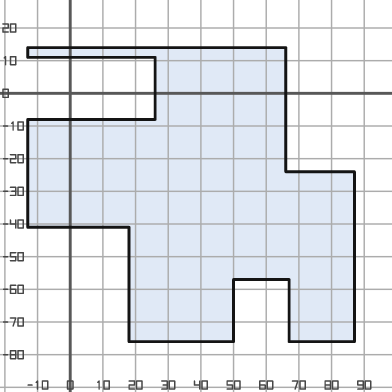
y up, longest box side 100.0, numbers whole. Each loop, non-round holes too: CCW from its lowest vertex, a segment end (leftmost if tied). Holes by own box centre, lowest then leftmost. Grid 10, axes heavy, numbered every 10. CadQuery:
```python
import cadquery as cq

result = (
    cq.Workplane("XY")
    .moveTo(18.0, -76.0)
    .lineTo(50.0, -76.0)
    .lineTo(50.0, -57.0)
    .lineTo(67.0, -57.0)
    .lineTo(67.0, -76.0)
    .lineTo(87.0, -76.0)
    .lineTo(87.0, -24.0)
    .lineTo(66.0, -24.0)
    .lineTo(66.0, 14.0)
    .lineTo(-13.0, 14.0)
    .lineTo(-13.0, 11.0)
    .lineTo(26.0, 11.0)
    .lineTo(26.0, -8.0)
    .lineTo(-13.0, -8.0)
    .lineTo(-13.0, -41.0)
    .lineTo(18.0, -41.0)
    .close()
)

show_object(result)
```